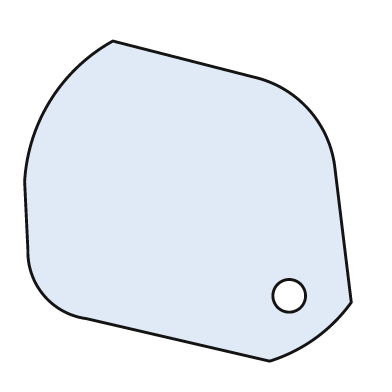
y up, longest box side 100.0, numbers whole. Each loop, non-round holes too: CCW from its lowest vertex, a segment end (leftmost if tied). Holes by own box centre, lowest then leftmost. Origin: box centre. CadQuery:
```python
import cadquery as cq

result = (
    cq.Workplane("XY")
    .moveTo(25.0, -49.0)
    .threePointArc((39.0, -42.0), (50.0, -31.0))
    .lineTo(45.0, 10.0)
    .threePointArc((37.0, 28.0), (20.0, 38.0))
    .lineTo(-23.0, 49.0)
    .threePointArc((-42.0, 31.0), (-50.0, 6.0))
    .lineTo(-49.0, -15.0)
    .threePointArc((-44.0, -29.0), (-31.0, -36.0))
    .close()
    .moveTo(31.0, -29.0)
    .circle(5.0)
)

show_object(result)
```